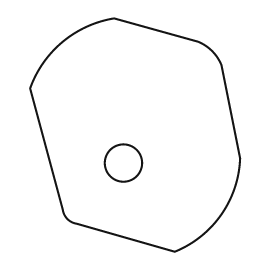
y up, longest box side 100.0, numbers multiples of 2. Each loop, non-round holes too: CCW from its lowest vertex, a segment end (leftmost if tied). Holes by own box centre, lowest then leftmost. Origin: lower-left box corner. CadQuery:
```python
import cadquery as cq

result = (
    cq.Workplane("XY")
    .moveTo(62.0, 0.0)
    .threePointArc((82.0, 16.0), (90.0, 40.0))
    .lineTo(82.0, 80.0)
    .threePointArc((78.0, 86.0), (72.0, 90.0))
    .lineTo(36.0, 100.0)
    .threePointArc((14.0, 90.0), (0.0, 70.0))
    .lineTo(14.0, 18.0)
    .threePointArc((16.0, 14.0), (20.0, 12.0))
    .close()
    .moveTo(40.0, 38.0)
    .circle(8.0)
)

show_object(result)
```